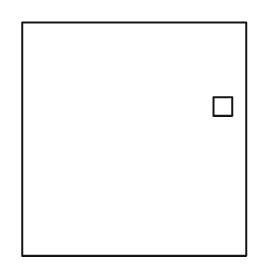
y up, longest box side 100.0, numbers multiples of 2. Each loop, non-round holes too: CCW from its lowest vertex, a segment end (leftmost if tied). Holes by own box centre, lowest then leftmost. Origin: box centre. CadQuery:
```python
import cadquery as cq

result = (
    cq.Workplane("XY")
    .moveTo(-48.0, -50.0)
    .lineTo(48.0, -50.0)
    .lineTo(48.0, 50.0)
    .lineTo(-48.0, 50.0)
    .close()
    .moveTo(34.0, 10.0)
    .lineTo(42.0, 10.0)
    .lineTo(42.0, 18.0)
    .lineTo(34.0, 18.0)
    .close()
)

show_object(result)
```